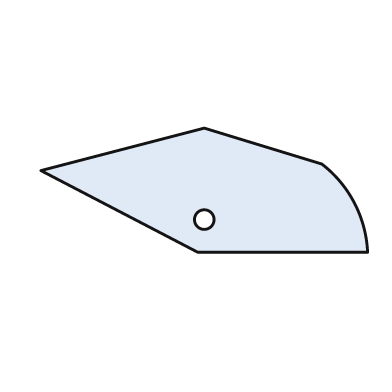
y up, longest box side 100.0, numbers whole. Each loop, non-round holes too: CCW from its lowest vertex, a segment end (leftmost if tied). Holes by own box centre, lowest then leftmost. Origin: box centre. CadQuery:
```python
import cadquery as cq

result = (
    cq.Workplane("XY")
    .moveTo(-2.0, -19.0)
    .lineTo(50.0, -19.0)
    .threePointArc((46.0, -4.0), (36.0, 8.0))
    .lineTo(0.0, 19.0)
    .lineTo(-50.0, 6.0)
    .close()
    .moveTo(0.0, -9.0)
    .circle(3.0)
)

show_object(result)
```